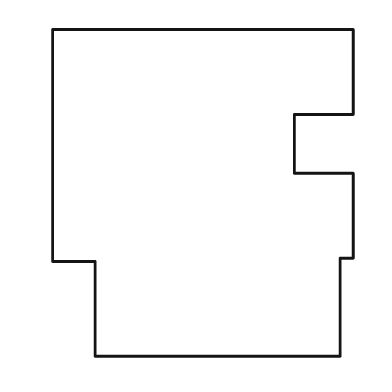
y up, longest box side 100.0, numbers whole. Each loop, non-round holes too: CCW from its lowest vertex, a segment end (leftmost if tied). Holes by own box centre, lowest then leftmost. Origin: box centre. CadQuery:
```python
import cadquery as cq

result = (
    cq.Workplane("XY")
    .moveTo(-33.0, -50.0)
    .lineTo(42.0, -50.0)
    .lineTo(42.0, -20.0)
    .lineTo(46.0, -20.0)
    .lineTo(46.0, 6.0)
    .lineTo(28.0, 6.0)
    .lineTo(28.0, 24.0)
    .lineTo(46.0, 24.0)
    .lineTo(46.0, 50.0)
    .lineTo(-46.0, 50.0)
    .lineTo(-46.0, -21.0)
    .lineTo(-33.0, -21.0)
    .close()
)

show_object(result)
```